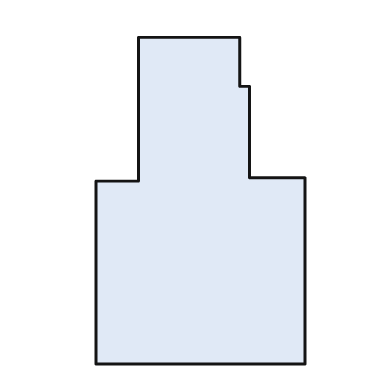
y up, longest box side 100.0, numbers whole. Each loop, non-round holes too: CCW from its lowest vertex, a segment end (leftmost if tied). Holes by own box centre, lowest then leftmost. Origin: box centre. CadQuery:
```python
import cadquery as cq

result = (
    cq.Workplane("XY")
    .moveTo(-32.0, -50.0)
    .lineTo(32.0, -50.0)
    .lineTo(32.0, 7.0)
    .lineTo(15.0, 7.0)
    .lineTo(15.0, 35.0)
    .lineTo(12.0, 35.0)
    .lineTo(12.0, 50.0)
    .lineTo(-19.0, 50.0)
    .lineTo(-19.0, 6.0)
    .lineTo(-32.0, 6.0)
    .close()
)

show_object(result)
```